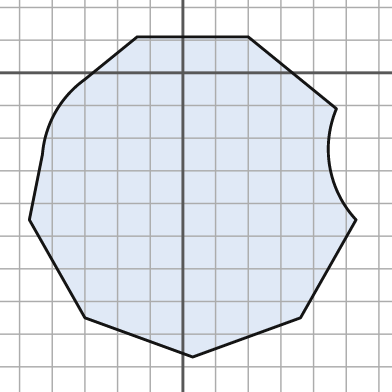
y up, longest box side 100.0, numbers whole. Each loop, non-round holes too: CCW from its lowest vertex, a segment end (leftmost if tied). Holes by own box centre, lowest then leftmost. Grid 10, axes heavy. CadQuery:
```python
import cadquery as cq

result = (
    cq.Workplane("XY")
    .moveTo(3.0, -87.0)
    .lineTo(36.0, -75.0)
    .lineTo(53.0, -45.0)
    .threePointArc((45.0, -29.0), (47.0, -11.0))
    .lineTo(20.0, 11.0)
    .lineTo(-14.0, 11.0)
    .lineTo(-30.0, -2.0)
    .threePointArc((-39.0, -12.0), (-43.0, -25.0))
    .lineTo(-47.0, -45.0)
    .lineTo(-30.0, -75.0)
    .close()
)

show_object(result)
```